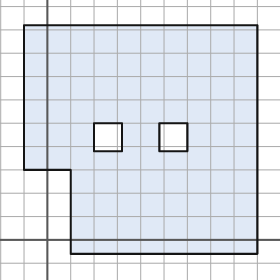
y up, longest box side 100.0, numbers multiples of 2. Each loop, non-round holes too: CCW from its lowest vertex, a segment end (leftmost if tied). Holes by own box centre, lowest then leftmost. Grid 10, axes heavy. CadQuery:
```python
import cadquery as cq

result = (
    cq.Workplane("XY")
    .moveTo(10.0, -6.0)
    .lineTo(90.0, -6.0)
    .lineTo(90.0, 92.0)
    .lineTo(-10.0, 92.0)
    .lineTo(-10.0, 30.0)
    .lineTo(10.0, 30.0)
    .close()
    .moveTo(20.0, 38.0)
    .lineTo(32.0, 38.0)
    .lineTo(32.0, 50.0)
    .lineTo(20.0, 50.0)
    .close()
    .moveTo(48.0, 38.0)
    .lineTo(60.0, 38.0)
    .lineTo(60.0, 50.0)
    .lineTo(48.0, 50.0)
    .close()
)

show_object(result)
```